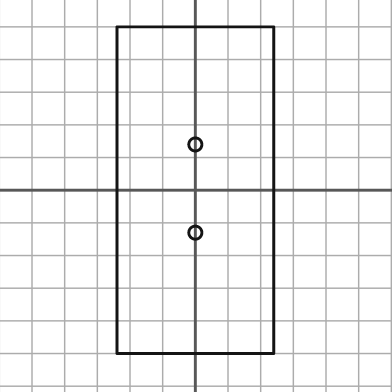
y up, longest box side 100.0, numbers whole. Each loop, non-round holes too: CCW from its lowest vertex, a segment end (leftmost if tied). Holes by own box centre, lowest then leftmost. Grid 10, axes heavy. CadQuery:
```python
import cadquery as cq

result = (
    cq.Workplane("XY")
    .moveTo(-24.0, -50.0)
    .lineTo(24.0, -50.0)
    .lineTo(24.0, 50.0)
    .lineTo(-24.0, 50.0)
    .close()
    .moveTo(0.0, -13.0)
    .circle(2.0)
    .moveTo(0.0, 14.0)
    .circle(2.0)
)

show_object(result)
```